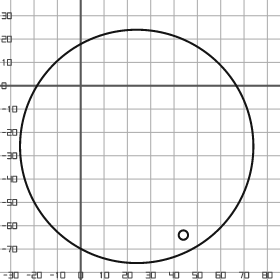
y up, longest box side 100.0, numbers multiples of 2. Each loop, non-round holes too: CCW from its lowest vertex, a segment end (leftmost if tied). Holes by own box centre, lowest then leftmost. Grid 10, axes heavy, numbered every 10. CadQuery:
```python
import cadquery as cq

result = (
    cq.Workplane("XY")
    .moveTo(24.0, -26.0)
    .circle(50.0)
    .moveTo(44.0, -64.0)
    .circle(2.0)
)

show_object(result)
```